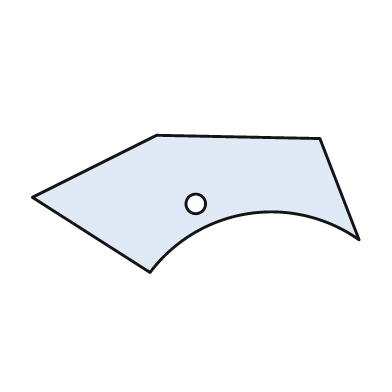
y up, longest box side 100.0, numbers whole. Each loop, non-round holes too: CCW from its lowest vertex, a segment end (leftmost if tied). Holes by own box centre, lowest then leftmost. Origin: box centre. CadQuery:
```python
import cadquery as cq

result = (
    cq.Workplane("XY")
    .moveTo(-14.0, -21.0)
    .threePointArc((16.0, -3.0), (50.0, -11.0))
    .lineTo(38.0, 20.0)
    .lineTo(-12.0, 21.0)
    .lineTo(-50.0, 2.0)
    .close()
    .moveTo(0.0, 0.0)
    .circle(3.0)
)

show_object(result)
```